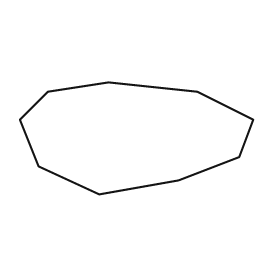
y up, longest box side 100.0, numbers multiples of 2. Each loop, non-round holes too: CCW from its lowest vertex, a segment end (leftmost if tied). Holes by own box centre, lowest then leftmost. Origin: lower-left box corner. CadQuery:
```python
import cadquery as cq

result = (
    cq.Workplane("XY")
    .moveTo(34.0, 0.0)
    .lineTo(68.0, 6.0)
    .lineTo(94.0, 16.0)
    .lineTo(100.0, 32.0)
    .lineTo(76.0, 44.0)
    .lineTo(38.0, 48.0)
    .lineTo(12.0, 44.0)
    .lineTo(0.0, 32.0)
    .lineTo(8.0, 12.0)
    .close()
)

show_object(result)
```